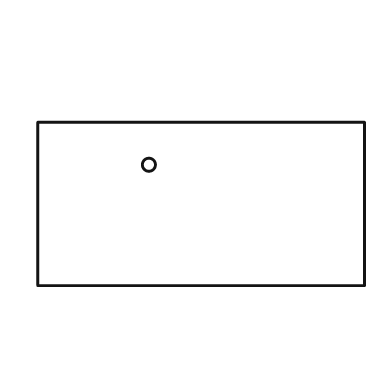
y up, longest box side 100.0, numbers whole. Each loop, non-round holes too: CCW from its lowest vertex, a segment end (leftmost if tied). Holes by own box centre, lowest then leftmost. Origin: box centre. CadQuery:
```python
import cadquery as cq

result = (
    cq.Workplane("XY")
    .moveTo(-50.0, -25.0)
    .lineTo(50.0, -25.0)
    .lineTo(50.0, 25.0)
    .lineTo(-50.0, 25.0)
    .close()
    .moveTo(-16.0, 12.0)
    .circle(2.0)
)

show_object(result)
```